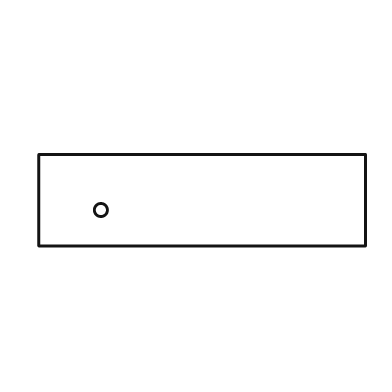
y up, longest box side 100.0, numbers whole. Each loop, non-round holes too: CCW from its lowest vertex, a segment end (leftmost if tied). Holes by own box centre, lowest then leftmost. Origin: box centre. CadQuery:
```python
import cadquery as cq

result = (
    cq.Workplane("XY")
    .moveTo(-50.0, -14.0)
    .lineTo(50.0, -14.0)
    .lineTo(50.0, 14.0)
    .lineTo(-50.0, 14.0)
    .close()
    .moveTo(-31.0, -3.0)
    .circle(2.0)
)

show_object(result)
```